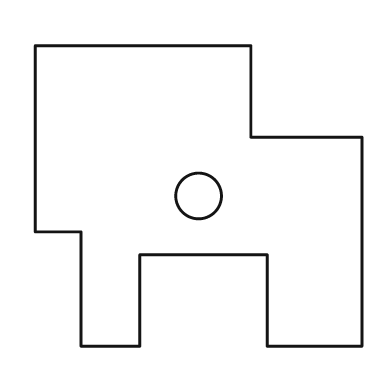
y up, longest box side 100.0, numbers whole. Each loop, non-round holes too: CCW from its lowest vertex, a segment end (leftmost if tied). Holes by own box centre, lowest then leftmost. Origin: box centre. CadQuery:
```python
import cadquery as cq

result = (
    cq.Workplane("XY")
    .moveTo(-36.0, -46.0)
    .lineTo(-18.0, -46.0)
    .lineTo(-18.0, -18.0)
    .lineTo(21.0, -18.0)
    .lineTo(21.0, -46.0)
    .lineTo(50.0, -46.0)
    .lineTo(50.0, 18.0)
    .lineTo(16.0, 18.0)
    .lineTo(16.0, 46.0)
    .lineTo(-50.0, 46.0)
    .lineTo(-50.0, -11.0)
    .lineTo(-36.0, -11.0)
    .close()
    .moveTo(0.0, 0.0)
    .circle(7.0)
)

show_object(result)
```